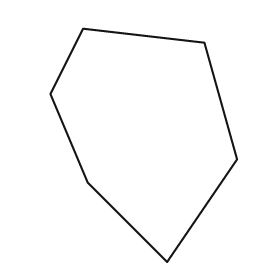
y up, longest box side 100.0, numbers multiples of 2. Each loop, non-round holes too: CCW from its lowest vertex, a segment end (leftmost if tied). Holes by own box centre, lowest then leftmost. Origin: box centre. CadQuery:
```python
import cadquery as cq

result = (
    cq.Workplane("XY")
    .moveTo(10.0, -50.0)
    .lineTo(40.0, -6.0)
    .lineTo(26.0, 44.0)
    .lineTo(-26.0, 50.0)
    .lineTo(-40.0, 22.0)
    .lineTo(-24.0, -16.0)
    .close()
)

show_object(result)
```